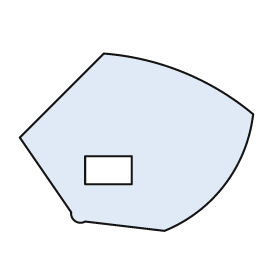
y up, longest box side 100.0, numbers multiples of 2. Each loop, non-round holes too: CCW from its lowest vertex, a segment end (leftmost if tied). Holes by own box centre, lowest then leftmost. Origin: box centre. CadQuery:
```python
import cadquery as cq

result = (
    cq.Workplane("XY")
    .moveTo(12.0, -38.0)
    .threePointArc((38.0, -18.0), (50.0, 12.0))
    .threePointArc((20.0, 30.0), (-14.0, 38.0))
    .lineTo(-50.0, 2.0)
    .lineTo(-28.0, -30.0)
    .threePointArc((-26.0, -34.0), (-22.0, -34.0))
    .close()
    .moveTo(-22.0, -18.0)
    .lineTo(-2.0, -18.0)
    .lineTo(-2.0, -6.0)
    .lineTo(-22.0, -6.0)
    .close()
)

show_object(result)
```